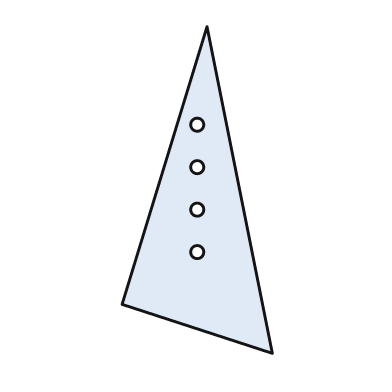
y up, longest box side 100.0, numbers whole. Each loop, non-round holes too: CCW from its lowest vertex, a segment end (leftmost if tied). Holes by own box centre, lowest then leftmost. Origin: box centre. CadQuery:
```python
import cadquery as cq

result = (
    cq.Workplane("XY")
    .moveTo(23.0, -50.0)
    .lineTo(3.0, 50.0)
    .lineTo(-23.0, -35.0)
    .close()
    .moveTo(0.0, -19.0)
    .circle(2.0)
    .moveTo(0.0, -6.0)
    .circle(2.0)
    .moveTo(0.0, 7.0)
    .circle(2.0)
    .moveTo(0.0, 20.0)
    .circle(2.0)
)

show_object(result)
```